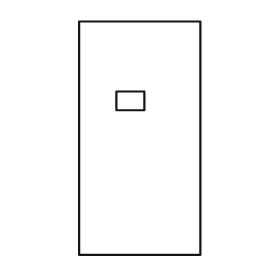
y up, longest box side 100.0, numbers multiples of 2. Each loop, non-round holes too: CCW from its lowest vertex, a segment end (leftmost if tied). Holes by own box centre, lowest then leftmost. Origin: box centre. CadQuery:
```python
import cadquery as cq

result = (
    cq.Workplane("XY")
    .moveTo(-26.0, -50.0)
    .lineTo(26.0, -50.0)
    .lineTo(26.0, 50.0)
    .lineTo(-26.0, 50.0)
    .close()
    .moveTo(-10.0, 12.0)
    .lineTo(2.0, 12.0)
    .lineTo(2.0, 20.0)
    .lineTo(-10.0, 20.0)
    .close()
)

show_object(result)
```